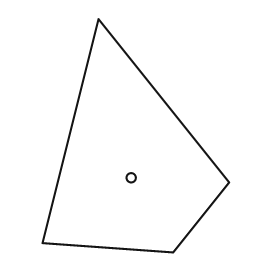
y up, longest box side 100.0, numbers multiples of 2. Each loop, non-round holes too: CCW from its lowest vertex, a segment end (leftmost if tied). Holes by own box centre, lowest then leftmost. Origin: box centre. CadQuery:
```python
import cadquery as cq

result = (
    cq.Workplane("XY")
    .moveTo(16.0, -50.0)
    .lineTo(40.0, -20.0)
    .lineTo(-16.0, 50.0)
    .lineTo(-40.0, -46.0)
    .close()
    .moveTo(-2.0, -18.0)
    .circle(2.0)
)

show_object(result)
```